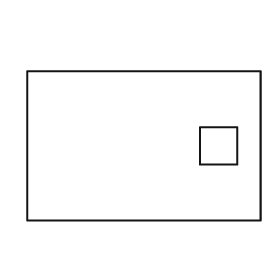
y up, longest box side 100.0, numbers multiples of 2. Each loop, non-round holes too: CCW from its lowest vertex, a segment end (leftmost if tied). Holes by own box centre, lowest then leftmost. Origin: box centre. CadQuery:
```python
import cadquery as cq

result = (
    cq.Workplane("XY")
    .moveTo(-50.0, -32.0)
    .lineTo(50.0, -32.0)
    .lineTo(50.0, 32.0)
    .lineTo(-50.0, 32.0)
    .close()
    .moveTo(24.0, -8.0)
    .lineTo(40.0, -8.0)
    .lineTo(40.0, 8.0)
    .lineTo(24.0, 8.0)
    .close()
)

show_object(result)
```